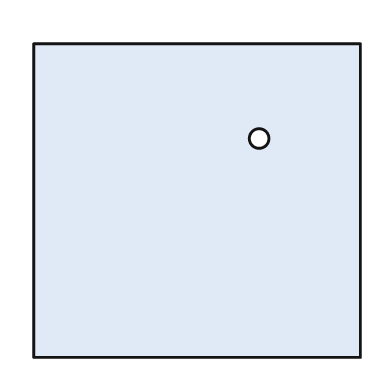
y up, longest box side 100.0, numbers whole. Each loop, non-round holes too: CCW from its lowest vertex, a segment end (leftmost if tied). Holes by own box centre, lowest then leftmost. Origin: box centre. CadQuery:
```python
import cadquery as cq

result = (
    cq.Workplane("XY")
    .moveTo(-50.0, -48.0)
    .lineTo(50.0, -48.0)
    .lineTo(50.0, 48.0)
    .lineTo(-50.0, 48.0)
    .close()
    .moveTo(19.0, 19.0)
    .circle(3.0)
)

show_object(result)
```